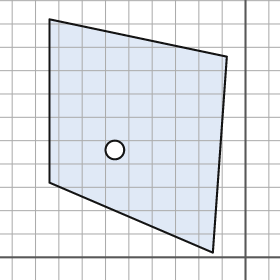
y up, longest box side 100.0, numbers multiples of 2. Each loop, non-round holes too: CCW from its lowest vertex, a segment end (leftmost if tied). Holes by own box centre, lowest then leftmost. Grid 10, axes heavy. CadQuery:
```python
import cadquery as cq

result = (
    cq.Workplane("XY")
    .moveTo(-14.0, 2.0)
    .lineTo(-8.0, 86.0)
    .lineTo(-84.0, 102.0)
    .lineTo(-84.0, 32.0)
    .close()
    .moveTo(-56.0, 46.0)
    .circle(4.0)
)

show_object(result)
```